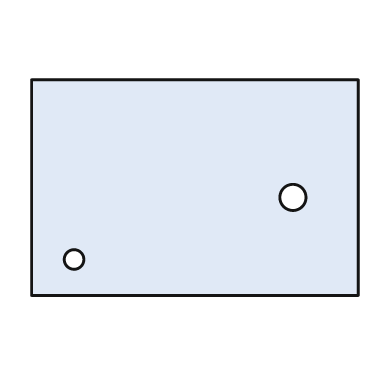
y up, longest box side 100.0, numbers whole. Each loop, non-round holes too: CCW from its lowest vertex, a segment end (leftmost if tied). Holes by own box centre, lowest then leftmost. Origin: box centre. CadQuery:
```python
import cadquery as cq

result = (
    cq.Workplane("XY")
    .moveTo(-50.0, -33.0)
    .lineTo(50.0, -33.0)
    .lineTo(50.0, 33.0)
    .lineTo(-50.0, 33.0)
    .close()
    .moveTo(-37.0, -22.0)
    .circle(3.0)
    .moveTo(30.0, -3.0)
    .circle(4.0)
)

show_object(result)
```